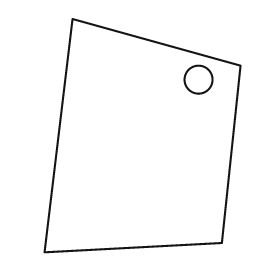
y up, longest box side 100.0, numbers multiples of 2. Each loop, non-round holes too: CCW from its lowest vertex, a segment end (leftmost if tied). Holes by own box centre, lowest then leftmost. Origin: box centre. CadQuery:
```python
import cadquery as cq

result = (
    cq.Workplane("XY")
    .moveTo(-42.0, -50.0)
    .lineTo(34.0, -46.0)
    .lineTo(42.0, 30.0)
    .lineTo(-30.0, 50.0)
    .close()
    .moveTo(24.0, 24.0)
    .circle(6.0)
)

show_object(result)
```